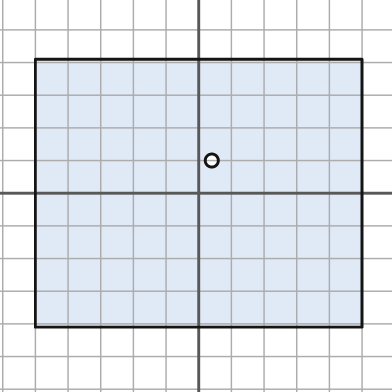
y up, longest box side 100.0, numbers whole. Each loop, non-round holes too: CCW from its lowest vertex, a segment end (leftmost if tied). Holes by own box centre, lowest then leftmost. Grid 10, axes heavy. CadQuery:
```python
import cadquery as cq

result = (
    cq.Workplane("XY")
    .moveTo(-50.0, -41.0)
    .lineTo(50.0, -41.0)
    .lineTo(50.0, 41.0)
    .lineTo(-50.0, 41.0)
    .close()
    .moveTo(4.0, 10.0)
    .circle(2.0)
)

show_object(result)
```